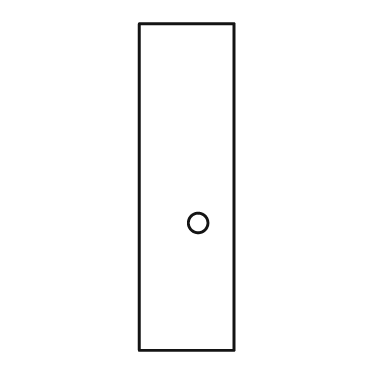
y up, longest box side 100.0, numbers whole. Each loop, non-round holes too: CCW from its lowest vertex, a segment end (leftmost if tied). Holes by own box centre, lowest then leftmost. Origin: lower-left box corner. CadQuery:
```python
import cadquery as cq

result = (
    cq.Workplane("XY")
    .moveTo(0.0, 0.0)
    .lineTo(29.0, 0.0)
    .lineTo(29.0, 100.0)
    .lineTo(0.0, 100.0)
    .close()
    .moveTo(18.0, 39.0)
    .circle(3.0)
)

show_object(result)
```